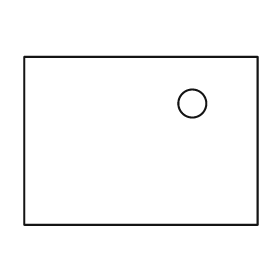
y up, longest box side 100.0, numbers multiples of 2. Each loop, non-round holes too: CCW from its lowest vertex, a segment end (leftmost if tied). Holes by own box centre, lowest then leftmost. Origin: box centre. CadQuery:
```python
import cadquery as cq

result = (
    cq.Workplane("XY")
    .moveTo(-50.0, -36.0)
    .lineTo(50.0, -36.0)
    .lineTo(50.0, 36.0)
    .lineTo(-50.0, 36.0)
    .close()
    .moveTo(22.0, 16.0)
    .circle(6.0)
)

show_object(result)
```